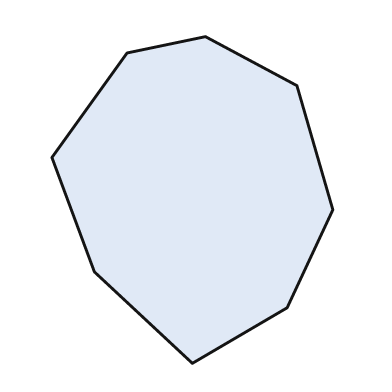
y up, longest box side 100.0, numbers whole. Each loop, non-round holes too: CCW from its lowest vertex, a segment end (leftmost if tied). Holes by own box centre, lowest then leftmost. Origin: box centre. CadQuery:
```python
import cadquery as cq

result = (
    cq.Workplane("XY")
    .moveTo(0.0, -50.0)
    .lineTo(29.0, -33.0)
    .lineTo(43.0, -3.0)
    .lineTo(32.0, 35.0)
    .lineTo(4.0, 50.0)
    .lineTo(-20.0, 45.0)
    .lineTo(-43.0, 13.0)
    .lineTo(-30.0, -22.0)
    .close()
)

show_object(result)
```